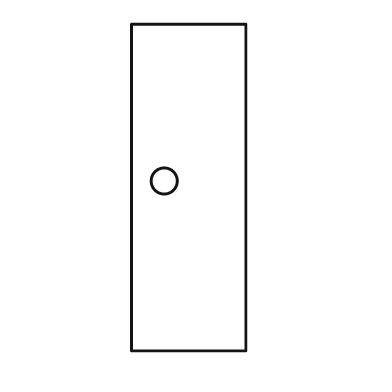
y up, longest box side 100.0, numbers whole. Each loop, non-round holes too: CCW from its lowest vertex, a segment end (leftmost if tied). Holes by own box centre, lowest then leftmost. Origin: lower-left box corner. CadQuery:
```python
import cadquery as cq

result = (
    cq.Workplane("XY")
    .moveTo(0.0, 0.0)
    .lineTo(35.0, 0.0)
    .lineTo(35.0, 100.0)
    .lineTo(0.0, 100.0)
    .close()
    .moveTo(10.0, 52.0)
    .circle(4.0)
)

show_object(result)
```